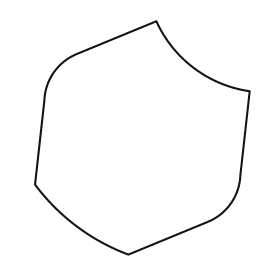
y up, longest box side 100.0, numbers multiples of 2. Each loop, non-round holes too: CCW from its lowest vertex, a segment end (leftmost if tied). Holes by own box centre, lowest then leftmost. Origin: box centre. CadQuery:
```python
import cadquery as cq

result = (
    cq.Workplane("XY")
    .moveTo(-6.0, -50.0)
    .lineTo(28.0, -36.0)
    .threePointArc((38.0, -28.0), (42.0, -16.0))
    .lineTo(46.0, 20.0)
    .threePointArc((22.0, 30.0), (6.0, 50.0))
    .lineTo(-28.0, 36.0)
    .threePointArc((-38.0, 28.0), (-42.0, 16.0))
    .lineTo(-46.0, -20.0)
    .threePointArc((-28.0, -38.0), (-6.0, -50.0))
    .close()
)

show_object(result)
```